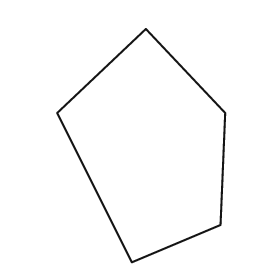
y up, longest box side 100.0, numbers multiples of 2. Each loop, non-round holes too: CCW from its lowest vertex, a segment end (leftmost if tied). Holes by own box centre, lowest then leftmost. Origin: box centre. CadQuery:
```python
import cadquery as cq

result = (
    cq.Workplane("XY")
    .moveTo(-4.0, -50.0)
    .lineTo(34.0, -34.0)
    .lineTo(36.0, 14.0)
    .lineTo(2.0, 50.0)
    .lineTo(-36.0, 14.0)
    .close()
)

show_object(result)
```